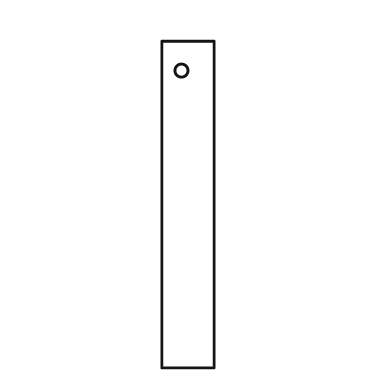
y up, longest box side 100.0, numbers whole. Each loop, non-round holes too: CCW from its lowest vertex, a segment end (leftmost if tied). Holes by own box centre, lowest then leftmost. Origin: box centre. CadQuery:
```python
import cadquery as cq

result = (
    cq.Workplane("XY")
    .moveTo(-8.0, -50.0)
    .lineTo(8.0, -50.0)
    .lineTo(8.0, 50.0)
    .lineTo(-8.0, 50.0)
    .close()
    .moveTo(-2.0, 41.0)
    .circle(2.0)
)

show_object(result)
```